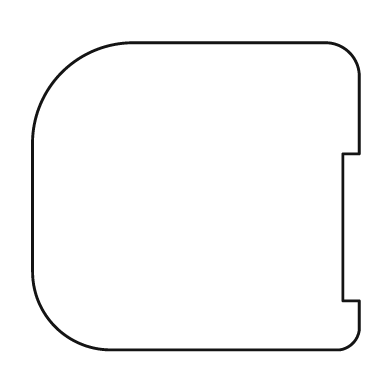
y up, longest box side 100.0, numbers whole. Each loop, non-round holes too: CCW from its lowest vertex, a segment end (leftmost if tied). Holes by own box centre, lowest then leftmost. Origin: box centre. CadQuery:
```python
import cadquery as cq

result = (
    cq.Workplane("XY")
    .moveTo(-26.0, -47.0)
    .lineTo(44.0, -47.0)
    .threePointArc((48.0, -45.0), (50.0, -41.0))
    .lineTo(50.0, -32.0)
    .lineTo(45.0, -32.0)
    .lineTo(45.0, 13.0)
    .lineTo(50.0, 13.0)
    .lineTo(50.0, 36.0)
    .threePointArc((47.0, 44.0), (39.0, 47.0))
    .lineTo(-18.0, 47.0)
    .threePointArc((-41.0, 38.0), (-50.0, 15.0))
    .lineTo(-50.0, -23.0)
    .threePointArc((-43.0, -40.0), (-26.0, -47.0))
    .close()
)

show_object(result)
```